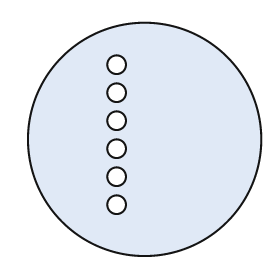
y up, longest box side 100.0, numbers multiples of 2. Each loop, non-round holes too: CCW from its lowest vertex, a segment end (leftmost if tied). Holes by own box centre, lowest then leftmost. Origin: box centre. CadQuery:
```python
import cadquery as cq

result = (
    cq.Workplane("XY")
    .moveTo(0.0, 0.0)
    .circle(50.0)
    .moveTo(-12.0, -28.0)
    .circle(4.0)
    .moveTo(-12.0, -16.0)
    .circle(4.0)
    .moveTo(-12.0, -4.0)
    .circle(4.0)
    .moveTo(-12.0, 8.0)
    .circle(4.0)
    .moveTo(-12.0, 20.0)
    .circle(4.0)
    .moveTo(-12.0, 32.0)
    .circle(4.0)
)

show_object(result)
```